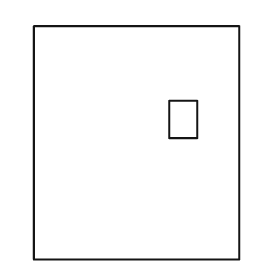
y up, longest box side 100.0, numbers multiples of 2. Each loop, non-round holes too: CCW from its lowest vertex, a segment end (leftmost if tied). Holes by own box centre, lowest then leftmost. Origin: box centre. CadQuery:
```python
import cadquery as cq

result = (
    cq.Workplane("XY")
    .moveTo(-44.0, -50.0)
    .lineTo(44.0, -50.0)
    .lineTo(44.0, 50.0)
    .lineTo(-44.0, 50.0)
    .close()
    .moveTo(14.0, 2.0)
    .lineTo(26.0, 2.0)
    .lineTo(26.0, 18.0)
    .lineTo(14.0, 18.0)
    .close()
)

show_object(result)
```